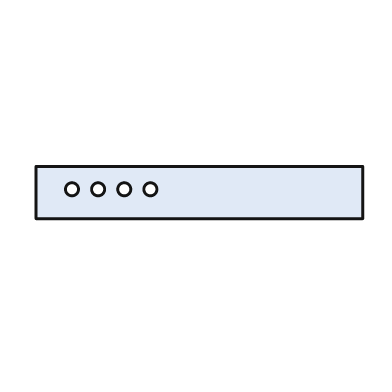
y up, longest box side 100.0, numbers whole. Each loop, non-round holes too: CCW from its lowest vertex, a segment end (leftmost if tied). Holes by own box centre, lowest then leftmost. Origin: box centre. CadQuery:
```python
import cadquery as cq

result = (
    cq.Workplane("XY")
    .moveTo(-50.0, -8.0)
    .lineTo(50.0, -8.0)
    .lineTo(50.0, 8.0)
    .lineTo(-50.0, 8.0)
    .close()
    .moveTo(-39.0, 1.0)
    .circle(2.0)
    .moveTo(-31.0, 1.0)
    .circle(2.0)
    .moveTo(-23.0, 1.0)
    .circle(2.0)
    .moveTo(-15.0, 1.0)
    .circle(2.0)
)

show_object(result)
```